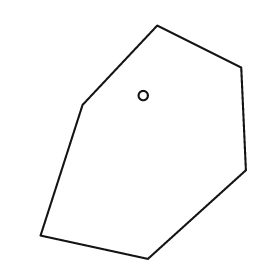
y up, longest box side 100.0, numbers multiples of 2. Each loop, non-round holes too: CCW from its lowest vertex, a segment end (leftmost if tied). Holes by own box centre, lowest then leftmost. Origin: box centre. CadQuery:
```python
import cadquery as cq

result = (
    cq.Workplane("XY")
    .moveTo(2.0, -50.0)
    .lineTo(44.0, -12.0)
    .lineTo(42.0, 32.0)
    .lineTo(6.0, 50.0)
    .lineTo(-26.0, 16.0)
    .lineTo(-44.0, -40.0)
    .close()
    .moveTo(0.0, 20.0)
    .circle(2.0)
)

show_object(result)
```